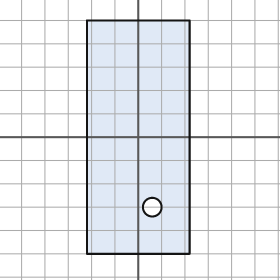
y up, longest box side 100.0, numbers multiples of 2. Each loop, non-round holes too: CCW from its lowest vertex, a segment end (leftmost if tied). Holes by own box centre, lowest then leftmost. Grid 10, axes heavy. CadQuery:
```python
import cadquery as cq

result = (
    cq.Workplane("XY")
    .moveTo(-22.0, -50.0)
    .lineTo(22.0, -50.0)
    .lineTo(22.0, 50.0)
    .lineTo(-22.0, 50.0)
    .close()
    .moveTo(6.0, -30.0)
    .circle(4.0)
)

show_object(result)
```